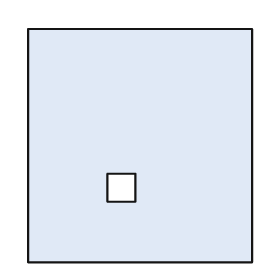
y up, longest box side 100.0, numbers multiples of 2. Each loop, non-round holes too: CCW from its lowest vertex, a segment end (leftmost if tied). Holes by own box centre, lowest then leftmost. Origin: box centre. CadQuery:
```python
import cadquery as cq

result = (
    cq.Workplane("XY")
    .moveTo(-48.0, -50.0)
    .lineTo(48.0, -50.0)
    .lineTo(48.0, 50.0)
    .lineTo(-48.0, 50.0)
    .close()
    .moveTo(-14.0, -24.0)
    .lineTo(-2.0, -24.0)
    .lineTo(-2.0, -12.0)
    .lineTo(-14.0, -12.0)
    .close()
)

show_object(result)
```